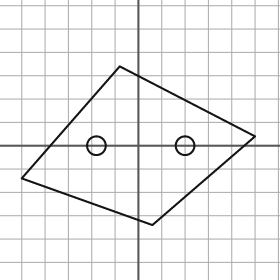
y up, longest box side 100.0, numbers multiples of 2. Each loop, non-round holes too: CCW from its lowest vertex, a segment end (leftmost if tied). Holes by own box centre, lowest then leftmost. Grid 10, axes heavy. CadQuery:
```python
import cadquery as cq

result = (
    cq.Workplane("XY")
    .moveTo(6.0, -34.0)
    .lineTo(50.0, 4.0)
    .lineTo(-8.0, 34.0)
    .lineTo(-50.0, -14.0)
    .close()
    .moveTo(-18.0, 0.0)
    .circle(4.0)
    .moveTo(20.0, 0.0)
    .circle(4.0)
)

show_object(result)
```